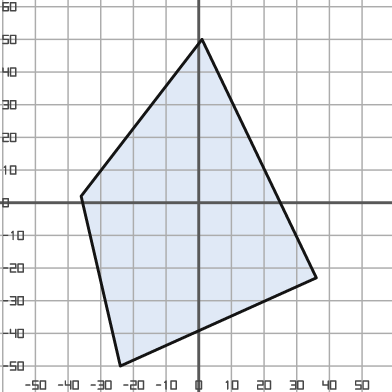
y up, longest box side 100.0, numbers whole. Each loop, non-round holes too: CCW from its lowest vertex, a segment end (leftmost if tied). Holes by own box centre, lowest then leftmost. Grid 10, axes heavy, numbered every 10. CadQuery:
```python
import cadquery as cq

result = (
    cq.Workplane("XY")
    .moveTo(-24.0, -50.0)
    .lineTo(36.0, -23.0)
    .lineTo(1.0, 50.0)
    .lineTo(-36.0, 2.0)
    .close()
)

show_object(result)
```